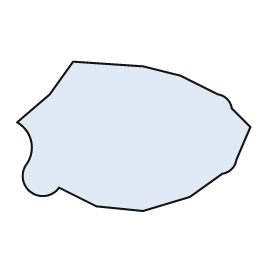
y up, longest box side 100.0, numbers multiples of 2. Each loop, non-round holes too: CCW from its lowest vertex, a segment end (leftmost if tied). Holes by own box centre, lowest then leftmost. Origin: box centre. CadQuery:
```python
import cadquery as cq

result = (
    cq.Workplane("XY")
    .moveTo(4.0, -32.0)
    .lineTo(24.0, -26.0)
    .lineTo(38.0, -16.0)
    .threePointArc((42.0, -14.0), (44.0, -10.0))
    .lineTo(50.0, 4.0)
    .lineTo(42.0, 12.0)
    .threePointArc((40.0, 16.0), (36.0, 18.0))
    .lineTo(20.0, 26.0)
    .lineTo(4.0, 30.0)
    .lineTo(-26.0, 32.0)
    .lineTo(-36.0, 18.0)
    .lineTo(-50.0, 6.0)
    .threePointArc((-44.0, -2.0), (-46.0, -12.0))
    .threePointArc((-44.0, -24.0), (-32.0, -22.0))
    .lineTo(-16.0, -30.0)
    .close()
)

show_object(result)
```